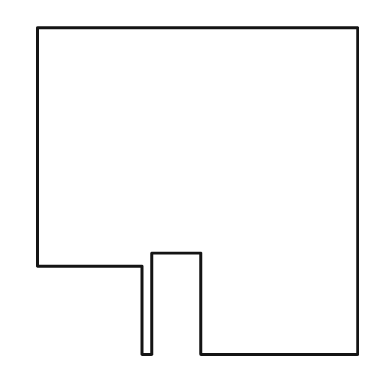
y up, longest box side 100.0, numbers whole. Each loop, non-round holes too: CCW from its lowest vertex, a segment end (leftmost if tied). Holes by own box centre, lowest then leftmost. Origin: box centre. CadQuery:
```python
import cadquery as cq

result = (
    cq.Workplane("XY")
    .moveTo(-17.0, -50.0)
    .lineTo(-14.0, -50.0)
    .lineTo(-14.0, -19.0)
    .lineTo(1.0, -19.0)
    .lineTo(1.0, -50.0)
    .lineTo(49.0, -50.0)
    .lineTo(49.0, 50.0)
    .lineTo(-49.0, 50.0)
    .lineTo(-49.0, -23.0)
    .lineTo(-17.0, -23.0)
    .close()
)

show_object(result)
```